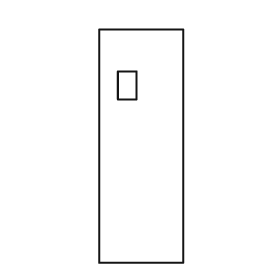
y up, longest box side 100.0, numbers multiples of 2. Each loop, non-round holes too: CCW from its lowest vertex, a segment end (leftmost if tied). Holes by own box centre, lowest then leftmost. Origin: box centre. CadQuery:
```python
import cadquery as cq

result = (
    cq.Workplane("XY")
    .moveTo(-18.0, -50.0)
    .lineTo(18.0, -50.0)
    .lineTo(18.0, 50.0)
    .lineTo(-18.0, 50.0)
    .close()
    .moveTo(-10.0, 20.0)
    .lineTo(-2.0, 20.0)
    .lineTo(-2.0, 32.0)
    .lineTo(-10.0, 32.0)
    .close()
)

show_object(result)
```